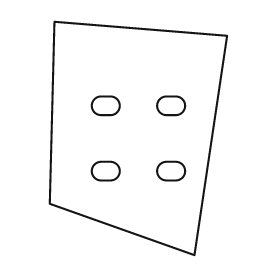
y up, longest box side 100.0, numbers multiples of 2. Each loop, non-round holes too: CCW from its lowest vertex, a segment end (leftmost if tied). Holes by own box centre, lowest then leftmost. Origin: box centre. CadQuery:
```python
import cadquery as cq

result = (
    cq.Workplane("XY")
    .moveTo(24.0, -50.0)
    .lineTo(38.0, 44.0)
    .lineTo(-36.0, 50.0)
    .lineTo(-38.0, -28.0)
    .close()
    .moveTo(-16.0, -18.0)
    .lineTo(-12.0, -18.0)
    .threePointArc((-8.0, -14.0), (-12.0, -10.0))
    .lineTo(-16.0, -10.0)
    .threePointArc((-20.0, -14.0), (-16.0, -18.0))
    .close()
    .moveTo(12.0, -18.0)
    .lineTo(16.0, -18.0)
    .threePointArc((20.0, -14.0), (16.0, -10.0))
    .lineTo(12.0, -10.0)
    .threePointArc((8.0, -14.0), (12.0, -18.0))
    .close()
    .moveTo(-16.0, 10.0)
    .lineTo(-12.0, 10.0)
    .threePointArc((-8.0, 14.0), (-12.0, 18.0))
    .lineTo(-16.0, 18.0)
    .threePointArc((-20.0, 14.0), (-16.0, 10.0))
    .close()
    .moveTo(12.0, 10.0)
    .lineTo(16.0, 10.0)
    .threePointArc((20.0, 14.0), (16.0, 18.0))
    .lineTo(12.0, 18.0)
    .threePointArc((8.0, 14.0), (12.0, 10.0))
    .close()
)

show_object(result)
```